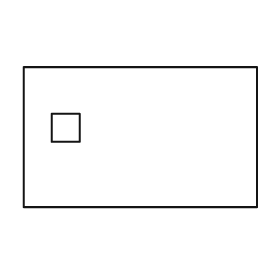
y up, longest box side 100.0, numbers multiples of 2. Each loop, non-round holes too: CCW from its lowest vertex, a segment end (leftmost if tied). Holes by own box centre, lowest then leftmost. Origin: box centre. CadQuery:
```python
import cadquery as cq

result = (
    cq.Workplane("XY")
    .moveTo(-50.0, -30.0)
    .lineTo(50.0, -30.0)
    .lineTo(50.0, 30.0)
    .lineTo(-50.0, 30.0)
    .close()
    .moveTo(-38.0, -2.0)
    .lineTo(-26.0, -2.0)
    .lineTo(-26.0, 10.0)
    .lineTo(-38.0, 10.0)
    .close()
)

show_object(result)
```